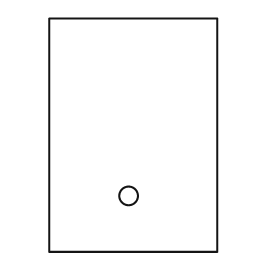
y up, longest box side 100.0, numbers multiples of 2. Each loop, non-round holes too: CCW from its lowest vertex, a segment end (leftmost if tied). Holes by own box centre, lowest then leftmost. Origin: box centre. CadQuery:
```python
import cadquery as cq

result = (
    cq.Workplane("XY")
    .moveTo(-36.0, -50.0)
    .lineTo(36.0, -50.0)
    .lineTo(36.0, 50.0)
    .lineTo(-36.0, 50.0)
    .close()
    .moveTo(-2.0, -26.0)
    .circle(4.0)
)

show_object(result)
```